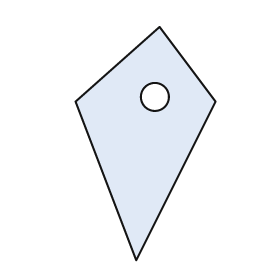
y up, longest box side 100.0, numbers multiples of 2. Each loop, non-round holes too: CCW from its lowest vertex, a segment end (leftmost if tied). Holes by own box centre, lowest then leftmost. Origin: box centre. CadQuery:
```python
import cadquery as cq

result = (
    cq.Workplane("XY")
    .moveTo(-4.0, -50.0)
    .lineTo(30.0, 18.0)
    .lineTo(6.0, 50.0)
    .lineTo(-30.0, 18.0)
    .close()
    .moveTo(4.0, 20.0)
    .circle(6.0)
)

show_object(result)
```